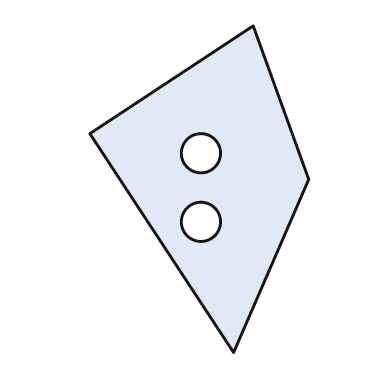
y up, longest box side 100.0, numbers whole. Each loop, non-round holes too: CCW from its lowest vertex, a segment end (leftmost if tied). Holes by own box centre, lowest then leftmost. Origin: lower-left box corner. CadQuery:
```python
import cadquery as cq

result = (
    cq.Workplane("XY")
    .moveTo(44.0, 0.0)
    .lineTo(67.0, 53.0)
    .lineTo(50.0, 100.0)
    .lineTo(0.0, 67.0)
    .close()
    .moveTo(34.0, 40.0)
    .circle(6.0)
    .moveTo(34.0, 61.0)
    .circle(6.0)
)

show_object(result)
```